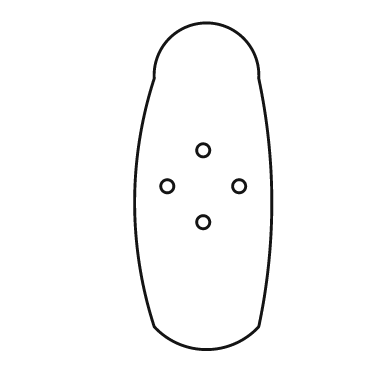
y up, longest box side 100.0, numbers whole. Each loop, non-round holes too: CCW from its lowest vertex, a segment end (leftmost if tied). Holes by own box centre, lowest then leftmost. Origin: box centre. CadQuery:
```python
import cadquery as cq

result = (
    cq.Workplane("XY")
    .moveTo(-15.0, -43.0)
    .threePointArc((1.0, -50.0), (17.0, -43.0))
    .threePointArc((21.0, -5.0), (17.0, 33.0))
    .threePointArc((1.0, 50.0), (-15.0, 33.0))
    .threePointArc((-21.0, -5.0), (-15.0, -43.0))
    .close()
    .moveTo(0.0, -11.0)
    .circle(2.0)
    .moveTo(-11.0, 0.0)
    .circle(2.0)
    .moveTo(11.0, 0.0)
    .circle(2.0)
    .moveTo(0.0, 11.0)
    .circle(2.0)
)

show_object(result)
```